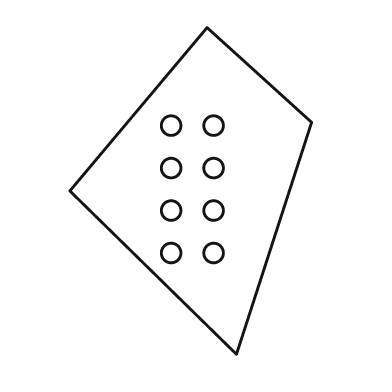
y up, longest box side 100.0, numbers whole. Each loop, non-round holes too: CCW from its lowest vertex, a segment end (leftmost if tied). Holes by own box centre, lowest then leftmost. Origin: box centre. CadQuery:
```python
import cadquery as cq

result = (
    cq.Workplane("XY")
    .moveTo(14.0, -50.0)
    .lineTo(37.0, 21.0)
    .lineTo(5.0, 50.0)
    .lineTo(-37.0, 0.0)
    .close()
    .moveTo(-6.0, -19.0)
    .circle(3.0)
    .moveTo(7.0, -19.0)
    .circle(3.0)
    .moveTo(-6.0, -6.0)
    .circle(3.0)
    .moveTo(7.0, -6.0)
    .circle(3.0)
    .moveTo(-6.0, 7.0)
    .circle(3.0)
    .moveTo(7.0, 7.0)
    .circle(3.0)
    .moveTo(-6.0, 20.0)
    .circle(3.0)
    .moveTo(7.0, 20.0)
    .circle(3.0)
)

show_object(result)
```